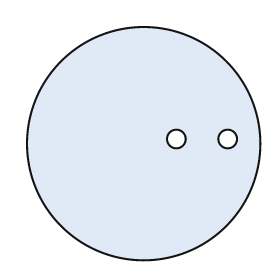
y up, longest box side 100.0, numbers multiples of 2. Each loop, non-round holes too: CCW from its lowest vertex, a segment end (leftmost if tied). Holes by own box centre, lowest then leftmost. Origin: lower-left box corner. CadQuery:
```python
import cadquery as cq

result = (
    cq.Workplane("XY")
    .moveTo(50.0, 50.0)
    .circle(50.0)
    .moveTo(64.0, 52.0)
    .circle(4.0)
    .moveTo(86.0, 52.0)
    .circle(4.0)
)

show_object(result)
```